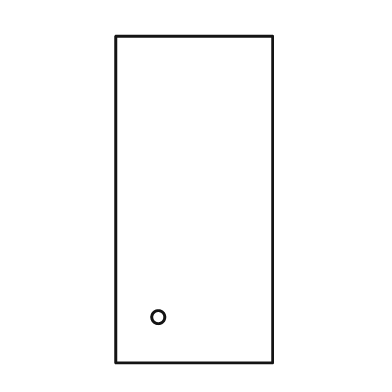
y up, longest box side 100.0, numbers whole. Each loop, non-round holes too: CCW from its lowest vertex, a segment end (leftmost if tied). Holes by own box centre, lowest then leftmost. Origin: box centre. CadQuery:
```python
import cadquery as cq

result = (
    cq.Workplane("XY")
    .moveTo(-24.0, -50.0)
    .lineTo(24.0, -50.0)
    .lineTo(24.0, 50.0)
    .lineTo(-24.0, 50.0)
    .close()
    .moveTo(-11.0, -36.0)
    .circle(2.0)
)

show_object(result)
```